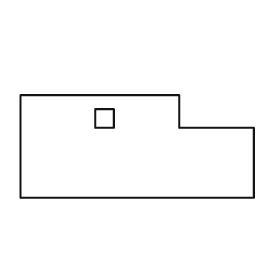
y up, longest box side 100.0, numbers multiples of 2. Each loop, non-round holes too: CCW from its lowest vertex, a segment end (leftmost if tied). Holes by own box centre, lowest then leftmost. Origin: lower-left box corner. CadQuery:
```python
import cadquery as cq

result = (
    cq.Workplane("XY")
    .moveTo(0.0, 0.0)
    .lineTo(100.0, 0.0)
    .lineTo(100.0, 30.0)
    .lineTo(68.0, 30.0)
    .lineTo(68.0, 44.0)
    .lineTo(0.0, 44.0)
    .close()
    .moveTo(32.0, 30.0)
    .lineTo(40.0, 30.0)
    .lineTo(40.0, 38.0)
    .lineTo(32.0, 38.0)
    .close()
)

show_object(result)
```